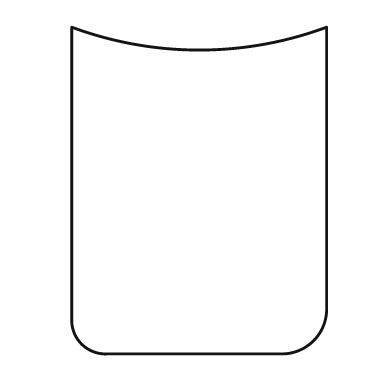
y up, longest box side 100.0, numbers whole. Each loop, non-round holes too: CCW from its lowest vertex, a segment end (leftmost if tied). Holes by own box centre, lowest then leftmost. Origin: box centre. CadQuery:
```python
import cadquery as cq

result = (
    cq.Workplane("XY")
    .moveTo(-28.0, -50.0)
    .lineTo(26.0, -50.0)
    .threePointArc((35.0, -46.0), (39.0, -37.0))
    .lineTo(39.0, 50.0)
    .threePointArc((0.0, 43.0), (-39.0, 50.0))
    .lineTo(-39.0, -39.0)
    .threePointArc((-36.0, -47.0), (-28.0, -50.0))
    .close()
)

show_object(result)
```